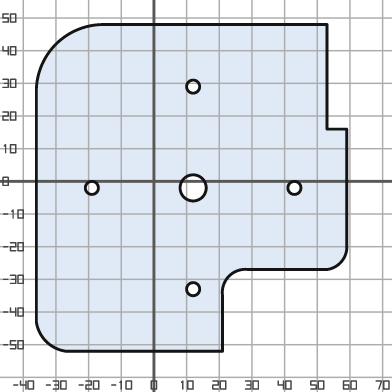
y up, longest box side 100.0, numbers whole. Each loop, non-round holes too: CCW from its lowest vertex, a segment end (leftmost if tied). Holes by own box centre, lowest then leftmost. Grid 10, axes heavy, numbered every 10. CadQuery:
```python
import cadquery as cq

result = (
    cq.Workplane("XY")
    .moveTo(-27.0, -52.0)
    .lineTo(21.0, -52.0)
    .lineTo(21.0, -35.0)
    .threePointArc((23.0, -29.0), (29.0, -27.0))
    .lineTo(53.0, -27.0)
    .threePointArc((57.0, -25.0), (59.0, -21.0))
    .lineTo(59.0, 16.0)
    .lineTo(53.0, 16.0)
    .lineTo(53.0, 48.0)
    .lineTo(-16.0, 48.0)
    .threePointArc((-30.0, 42.0), (-36.0, 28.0))
    .lineTo(-36.0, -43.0)
    .threePointArc((-33.0, -49.0), (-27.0, -52.0))
    .close()
    .moveTo(12.0, -33.0)
    .circle(2.0)
    .moveTo(-19.0, -2.0)
    .circle(2.0)
    .moveTo(12.0, -2.0)
    .circle(4.0)
    .moveTo(43.0, -2.0)
    .circle(2.0)
    .moveTo(12.0, 29.0)
    .circle(2.0)
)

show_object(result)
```